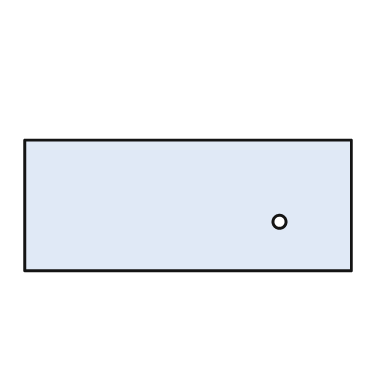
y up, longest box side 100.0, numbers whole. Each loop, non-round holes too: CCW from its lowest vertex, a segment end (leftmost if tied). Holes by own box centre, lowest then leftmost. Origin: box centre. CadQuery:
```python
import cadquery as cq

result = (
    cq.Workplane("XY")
    .moveTo(-50.0, -20.0)
    .lineTo(50.0, -20.0)
    .lineTo(50.0, 20.0)
    .lineTo(-50.0, 20.0)
    .close()
    .moveTo(28.0, -5.0)
    .circle(2.0)
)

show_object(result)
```